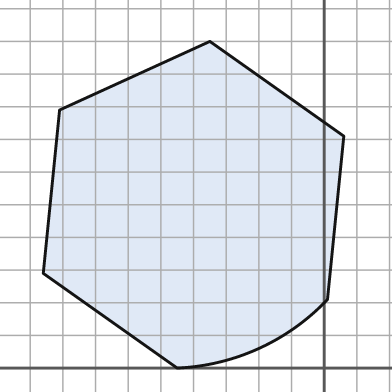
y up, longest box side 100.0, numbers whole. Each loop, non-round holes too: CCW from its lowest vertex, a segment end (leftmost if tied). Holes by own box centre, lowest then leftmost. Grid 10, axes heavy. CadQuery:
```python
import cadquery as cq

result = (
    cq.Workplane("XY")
    .moveTo(-45.0, 0.0)
    .threePointArc((-20.0, 6.0), (1.0, 21.0))
    .lineTo(6.0, 71.0)
    .lineTo(-35.0, 100.0)
    .lineTo(-81.0, 79.0)
    .lineTo(-86.0, 29.0)
    .close()
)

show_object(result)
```